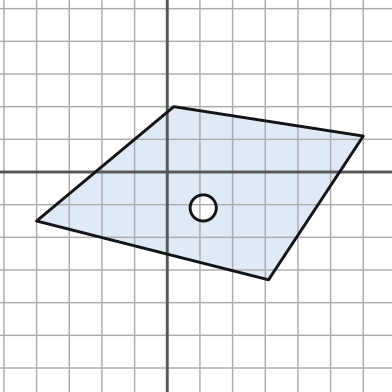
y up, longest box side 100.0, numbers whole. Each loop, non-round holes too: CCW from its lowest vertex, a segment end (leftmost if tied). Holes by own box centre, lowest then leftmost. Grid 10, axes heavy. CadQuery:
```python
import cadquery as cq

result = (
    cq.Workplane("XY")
    .moveTo(31.0, -33.0)
    .lineTo(60.0, 11.0)
    .lineTo(2.0, 20.0)
    .lineTo(-40.0, -15.0)
    .close()
    .moveTo(11.0, -11.0)
    .circle(4.0)
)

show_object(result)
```